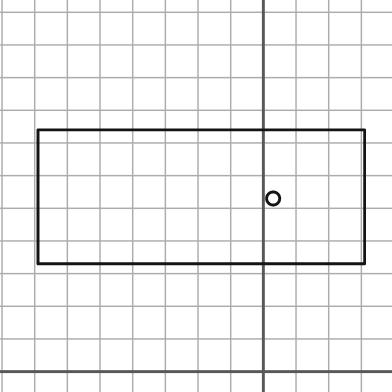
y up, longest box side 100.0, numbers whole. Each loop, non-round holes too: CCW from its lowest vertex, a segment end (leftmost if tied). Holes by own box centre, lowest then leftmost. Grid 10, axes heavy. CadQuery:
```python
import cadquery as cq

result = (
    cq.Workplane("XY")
    .moveTo(-69.0, 33.0)
    .lineTo(31.0, 33.0)
    .lineTo(31.0, 74.0)
    .lineTo(-69.0, 74.0)
    .close()
    .moveTo(3.0, 53.0)
    .circle(2.0)
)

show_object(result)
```